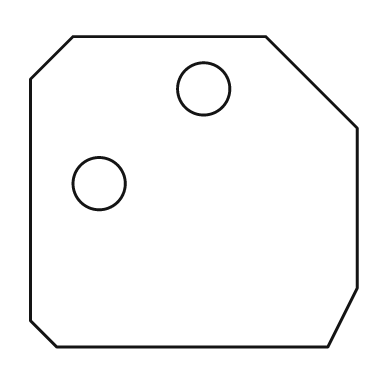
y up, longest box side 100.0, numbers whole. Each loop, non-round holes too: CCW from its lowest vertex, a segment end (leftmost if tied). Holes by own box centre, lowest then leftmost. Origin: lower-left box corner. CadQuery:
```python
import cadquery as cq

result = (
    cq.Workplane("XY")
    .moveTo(8.0, 0.0)
    .lineTo(91.0, 0.0)
    .lineTo(100.0, 18.0)
    .lineTo(100.0, 67.0)
    .lineTo(72.0, 95.0)
    .lineTo(13.0, 95.0)
    .lineTo(0.0, 82.0)
    .lineTo(0.0, 8.0)
    .close()
    .moveTo(21.0, 50.0)
    .circle(8.0)
    .moveTo(53.0, 79.0)
    .circle(8.0)
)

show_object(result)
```